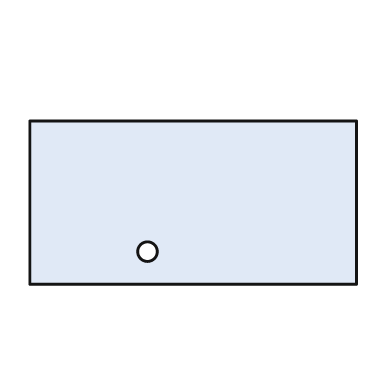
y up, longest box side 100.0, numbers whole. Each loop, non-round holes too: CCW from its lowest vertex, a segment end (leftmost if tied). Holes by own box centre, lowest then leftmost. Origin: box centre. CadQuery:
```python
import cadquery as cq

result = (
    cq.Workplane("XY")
    .moveTo(-50.0, -25.0)
    .lineTo(50.0, -25.0)
    .lineTo(50.0, 25.0)
    .lineTo(-50.0, 25.0)
    .close()
    .moveTo(-14.0, -15.0)
    .circle(3.0)
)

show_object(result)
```